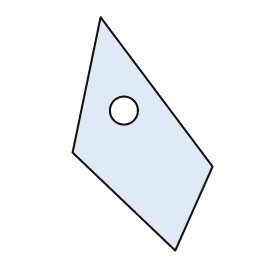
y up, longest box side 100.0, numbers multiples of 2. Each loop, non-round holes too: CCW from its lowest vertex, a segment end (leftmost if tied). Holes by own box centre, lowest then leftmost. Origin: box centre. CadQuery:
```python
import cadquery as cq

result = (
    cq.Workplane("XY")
    .moveTo(14.0, -50.0)
    .lineTo(30.0, -14.0)
    .lineTo(-18.0, 50.0)
    .lineTo(-30.0, -8.0)
    .close()
    .moveTo(-8.0, 10.0)
    .circle(6.0)
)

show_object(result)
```